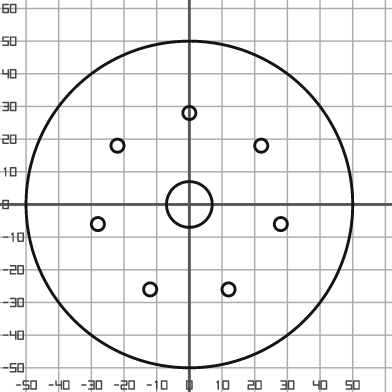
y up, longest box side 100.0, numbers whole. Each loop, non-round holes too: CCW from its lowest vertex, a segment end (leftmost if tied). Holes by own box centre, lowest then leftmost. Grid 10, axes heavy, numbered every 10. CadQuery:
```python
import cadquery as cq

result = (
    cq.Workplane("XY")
    .moveTo(0.0, 0.0)
    .circle(50.0)
    .moveTo(-12.0, -26.0)
    .circle(2.0)
    .moveTo(12.0, -26.0)
    .circle(2.0)
    .moveTo(-28.0, -6.0)
    .circle(2.0)
    .moveTo(28.0, -6.0)
    .circle(2.0)
    .moveTo(0.0, 0.0)
    .circle(7.0)
    .moveTo(-22.0, 18.0)
    .circle(2.0)
    .moveTo(22.0, 18.0)
    .circle(2.0)
    .moveTo(0.0, 28.0)
    .circle(2.0)
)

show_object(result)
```